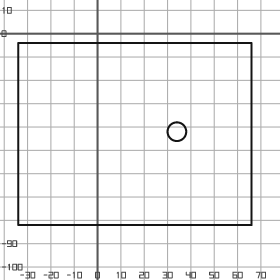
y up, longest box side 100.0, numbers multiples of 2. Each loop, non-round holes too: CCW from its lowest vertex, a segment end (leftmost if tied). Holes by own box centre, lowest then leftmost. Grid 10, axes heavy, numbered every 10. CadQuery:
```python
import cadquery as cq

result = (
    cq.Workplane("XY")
    .moveTo(-34.0, -82.0)
    .lineTo(66.0, -82.0)
    .lineTo(66.0, -4.0)
    .lineTo(-34.0, -4.0)
    .close()
    .moveTo(34.0, -42.0)
    .circle(4.0)
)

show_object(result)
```